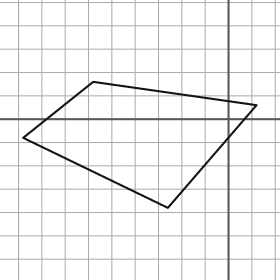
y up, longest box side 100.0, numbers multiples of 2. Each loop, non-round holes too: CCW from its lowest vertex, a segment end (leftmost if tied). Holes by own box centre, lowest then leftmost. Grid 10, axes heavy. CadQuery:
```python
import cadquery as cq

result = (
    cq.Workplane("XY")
    .moveTo(-26.0, -38.0)
    .lineTo(12.0, 6.0)
    .lineTo(-58.0, 16.0)
    .lineTo(-88.0, -8.0)
    .close()
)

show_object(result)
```